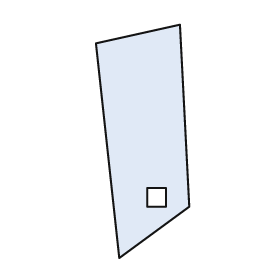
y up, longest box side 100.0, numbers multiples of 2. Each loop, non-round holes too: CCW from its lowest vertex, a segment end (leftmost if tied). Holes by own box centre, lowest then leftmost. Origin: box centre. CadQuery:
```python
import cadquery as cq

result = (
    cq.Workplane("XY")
    .moveTo(-10.0, -50.0)
    .lineTo(20.0, -28.0)
    .lineTo(16.0, 50.0)
    .lineTo(-20.0, 42.0)
    .close()
    .moveTo(2.0, -28.0)
    .lineTo(10.0, -28.0)
    .lineTo(10.0, -20.0)
    .lineTo(2.0, -20.0)
    .close()
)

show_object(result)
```